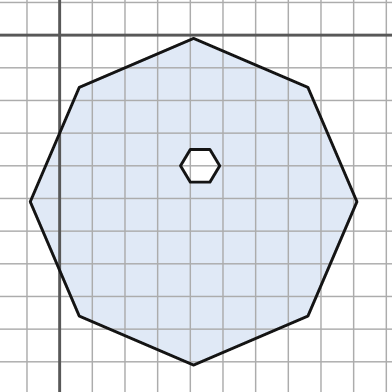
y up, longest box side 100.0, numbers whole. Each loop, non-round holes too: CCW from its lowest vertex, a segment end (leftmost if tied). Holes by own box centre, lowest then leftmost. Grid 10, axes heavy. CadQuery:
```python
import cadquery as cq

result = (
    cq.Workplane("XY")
    .moveTo(41.0, -101.0)
    .lineTo(76.0, -86.0)
    .lineTo(91.0, -51.0)
    .lineTo(76.0, -16.0)
    .lineTo(41.0, -1.0)
    .lineTo(6.0, -16.0)
    .lineTo(-9.0, -51.0)
    .lineTo(6.0, -86.0)
    .close()
    .moveTo(40.0, -45.0)
    .lineTo(46.0, -45.0)
    .lineTo(49.0, -40.0)
    .lineTo(46.0, -35.0)
    .lineTo(40.0, -35.0)
    .lineTo(37.0, -40.0)
    .close()
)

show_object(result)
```